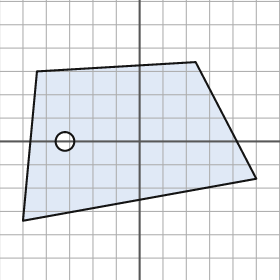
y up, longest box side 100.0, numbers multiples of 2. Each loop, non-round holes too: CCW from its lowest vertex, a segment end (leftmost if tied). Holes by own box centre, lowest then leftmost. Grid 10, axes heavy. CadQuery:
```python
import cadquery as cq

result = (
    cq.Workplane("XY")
    .moveTo(-50.0, -34.0)
    .lineTo(50.0, -16.0)
    .lineTo(24.0, 34.0)
    .lineTo(-44.0, 30.0)
    .close()
    .moveTo(-32.0, 0.0)
    .circle(4.0)
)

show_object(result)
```